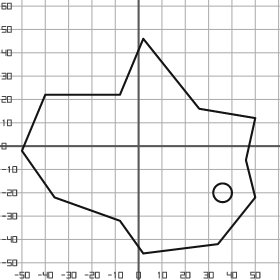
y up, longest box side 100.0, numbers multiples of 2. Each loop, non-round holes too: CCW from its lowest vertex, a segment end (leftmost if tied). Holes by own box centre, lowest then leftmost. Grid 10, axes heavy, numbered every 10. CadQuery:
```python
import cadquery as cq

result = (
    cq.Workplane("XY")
    .moveTo(2.0, -46.0)
    .lineTo(34.0, -42.0)
    .lineTo(50.0, -22.0)
    .lineTo(46.0, -6.0)
    .lineTo(50.0, 12.0)
    .lineTo(26.0, 16.0)
    .lineTo(2.0, 46.0)
    .lineTo(-8.0, 22.0)
    .lineTo(-40.0, 22.0)
    .lineTo(-50.0, -2.0)
    .lineTo(-36.0, -22.0)
    .lineTo(-8.0, -32.0)
    .close()
    .moveTo(36.0, -20.0)
    .circle(4.0)
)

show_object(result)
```